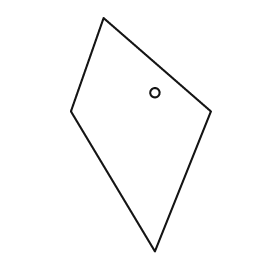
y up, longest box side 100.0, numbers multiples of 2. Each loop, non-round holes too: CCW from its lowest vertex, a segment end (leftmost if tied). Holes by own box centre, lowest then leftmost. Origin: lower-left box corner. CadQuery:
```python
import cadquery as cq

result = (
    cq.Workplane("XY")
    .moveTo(36.0, 0.0)
    .lineTo(60.0, 60.0)
    .lineTo(14.0, 100.0)
    .lineTo(0.0, 60.0)
    .close()
    .moveTo(36.0, 68.0)
    .circle(2.0)
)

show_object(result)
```